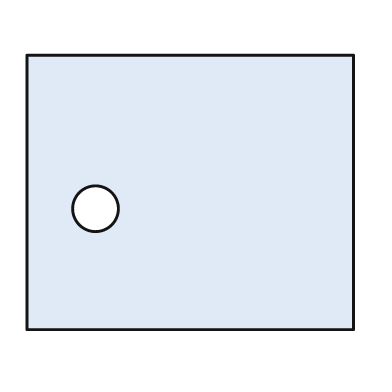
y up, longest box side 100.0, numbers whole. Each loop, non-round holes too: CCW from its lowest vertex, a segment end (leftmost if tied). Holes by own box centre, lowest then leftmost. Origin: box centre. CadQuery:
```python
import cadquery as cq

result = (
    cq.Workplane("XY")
    .moveTo(-50.0, -42.0)
    .lineTo(50.0, -42.0)
    .lineTo(50.0, 42.0)
    .lineTo(-50.0, 42.0)
    .close()
    .moveTo(-29.0, -5.0)
    .circle(7.0)
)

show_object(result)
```